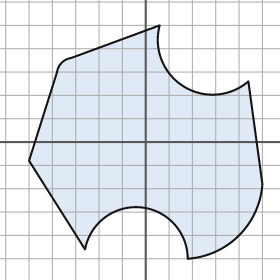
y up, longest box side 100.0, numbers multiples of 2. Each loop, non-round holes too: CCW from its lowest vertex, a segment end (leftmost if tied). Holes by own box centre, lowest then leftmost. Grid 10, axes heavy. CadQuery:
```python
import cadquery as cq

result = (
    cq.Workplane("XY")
    .moveTo(18.0, -50.0)
    .threePointArc((40.0, -40.0), (50.0, -18.0))
    .lineTo(44.0, 26.0)
    .threePointArc((16.0, 24.0), (6.0, 50.0))
    .lineTo(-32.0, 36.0)
    .threePointArc((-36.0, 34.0), (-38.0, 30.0))
    .lineTo(-50.0, -8.0)
    .lineTo(-26.0, -46.0)
    .threePointArc((-2.0, -28.0), (18.0, -50.0))
    .close()
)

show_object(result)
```